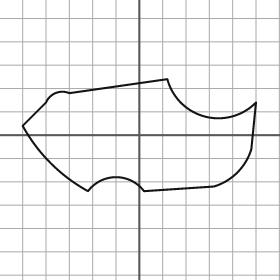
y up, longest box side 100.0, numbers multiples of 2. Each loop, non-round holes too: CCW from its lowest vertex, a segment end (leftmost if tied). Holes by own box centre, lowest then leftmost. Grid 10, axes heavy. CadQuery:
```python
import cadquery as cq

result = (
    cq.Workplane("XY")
    .moveTo(-22.0, -24.0)
    .threePointArc((-10.0, -18.0), (2.0, -24.0))
    .lineTo(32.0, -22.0)
    .threePointArc((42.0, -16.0), (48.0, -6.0))
    .lineTo(50.0, 14.0)
    .threePointArc((28.0, 8.0), (12.0, 24.0))
    .lineTo(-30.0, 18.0)
    .threePointArc((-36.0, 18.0), (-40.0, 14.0))
    .lineTo(-50.0, 4.0)
    .threePointArc((-38.0, -12.0), (-22.0, -24.0))
    .close()
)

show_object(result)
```